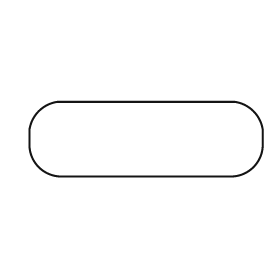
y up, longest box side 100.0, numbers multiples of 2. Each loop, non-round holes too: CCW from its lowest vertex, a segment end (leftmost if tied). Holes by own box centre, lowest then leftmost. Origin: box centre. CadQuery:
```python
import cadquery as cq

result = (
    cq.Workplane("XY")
    .moveTo(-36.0, -16.0)
    .lineTo(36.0, -16.0)
    .threePointArc((46.0, -12.0), (50.0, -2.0))
    .lineTo(50.0, 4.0)
    .threePointArc((46.0, 12.0), (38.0, 16.0))
    .lineTo(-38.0, 16.0)
    .threePointArc((-46.0, 12.0), (-50.0, 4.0))
    .lineTo(-50.0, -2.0)
    .threePointArc((-46.0, -12.0), (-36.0, -16.0))
    .close()
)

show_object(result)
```